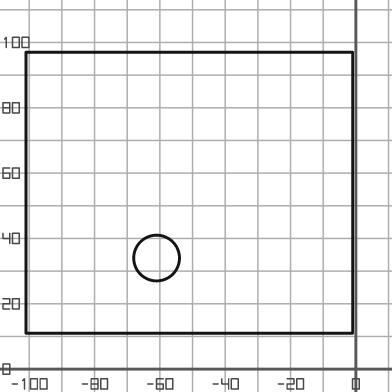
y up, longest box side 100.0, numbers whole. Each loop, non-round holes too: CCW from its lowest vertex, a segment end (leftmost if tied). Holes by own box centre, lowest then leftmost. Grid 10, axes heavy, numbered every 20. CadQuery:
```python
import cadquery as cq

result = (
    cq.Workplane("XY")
    .moveTo(-101.0, 11.0)
    .lineTo(-1.0, 11.0)
    .lineTo(-1.0, 97.0)
    .lineTo(-101.0, 97.0)
    .close()
    .moveTo(-61.0, 34.0)
    .circle(7.0)
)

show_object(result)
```